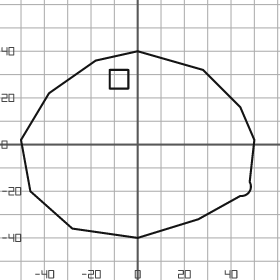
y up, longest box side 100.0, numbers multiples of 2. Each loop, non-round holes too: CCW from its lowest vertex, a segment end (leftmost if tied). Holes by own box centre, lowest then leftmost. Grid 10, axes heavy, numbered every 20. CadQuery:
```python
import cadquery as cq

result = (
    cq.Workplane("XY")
    .moveTo(0.0, -40.0)
    .lineTo(26.0, -32.0)
    .lineTo(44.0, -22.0)
    .threePointArc((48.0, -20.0), (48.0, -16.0))
    .lineTo(50.0, 2.0)
    .lineTo(44.0, 16.0)
    .lineTo(28.0, 32.0)
    .lineTo(0.0, 40.0)
    .lineTo(-18.0, 36.0)
    .lineTo(-38.0, 22.0)
    .lineTo(-50.0, 2.0)
    .lineTo(-46.0, -20.0)
    .lineTo(-28.0, -36.0)
    .close()
    .moveTo(-12.0, 24.0)
    .lineTo(-4.0, 24.0)
    .lineTo(-4.0, 32.0)
    .lineTo(-12.0, 32.0)
    .close()
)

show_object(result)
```